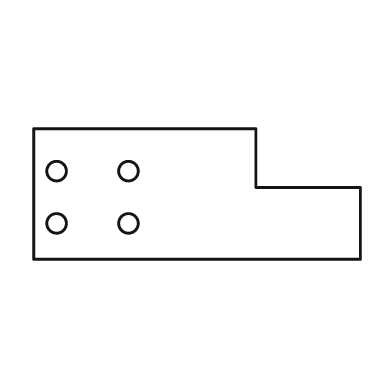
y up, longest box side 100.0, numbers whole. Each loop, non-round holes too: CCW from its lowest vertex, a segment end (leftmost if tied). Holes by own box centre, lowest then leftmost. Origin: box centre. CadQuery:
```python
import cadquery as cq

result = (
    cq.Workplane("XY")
    .moveTo(-50.0, -20.0)
    .lineTo(50.0, -20.0)
    .lineTo(50.0, 2.0)
    .lineTo(18.0, 2.0)
    .lineTo(18.0, 20.0)
    .lineTo(-50.0, 20.0)
    .close()
    .moveTo(-43.0, -9.0)
    .circle(3.0)
    .moveTo(-21.0, -9.0)
    .circle(3.0)
    .moveTo(-43.0, 7.0)
    .circle(3.0)
    .moveTo(-21.0, 7.0)
    .circle(3.0)
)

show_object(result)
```